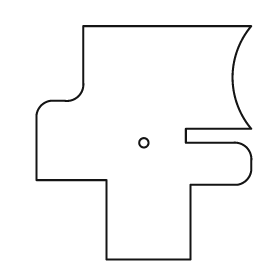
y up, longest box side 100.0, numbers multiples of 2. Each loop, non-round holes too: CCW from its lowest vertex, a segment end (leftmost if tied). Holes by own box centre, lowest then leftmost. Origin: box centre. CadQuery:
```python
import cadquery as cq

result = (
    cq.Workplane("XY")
    .moveTo(-16.0, -50.0)
    .lineTo(20.0, -50.0)
    .lineTo(20.0, -18.0)
    .lineTo(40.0, -18.0)
    .threePointArc((44.0, -16.0), (46.0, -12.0))
    .lineTo(46.0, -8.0)
    .threePointArc((44.0, -2.0), (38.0, 0.0))
    .lineTo(18.0, 0.0)
    .lineTo(18.0, 6.0)
    .lineTo(46.0, 6.0)
    .threePointArc((38.0, 28.0), (46.0, 50.0))
    .lineTo(-26.0, 50.0)
    .lineTo(-26.0, 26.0)
    .threePointArc((-28.0, 20.0), (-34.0, 18.0))
    .lineTo(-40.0, 18.0)
    .threePointArc((-44.0, 16.0), (-46.0, 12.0))
    .lineTo(-46.0, -16.0)
    .lineTo(-16.0, -16.0)
    .close()
    .moveTo(0.0, 0.0)
    .circle(2.0)
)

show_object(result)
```